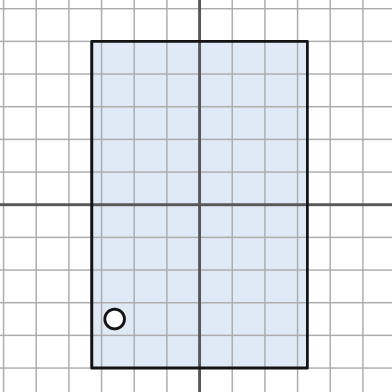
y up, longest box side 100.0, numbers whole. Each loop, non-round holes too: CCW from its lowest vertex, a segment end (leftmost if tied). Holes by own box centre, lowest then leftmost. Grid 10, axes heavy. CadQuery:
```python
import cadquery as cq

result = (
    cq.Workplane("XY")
    .moveTo(-33.0, -50.0)
    .lineTo(33.0, -50.0)
    .lineTo(33.0, 50.0)
    .lineTo(-33.0, 50.0)
    .close()
    .moveTo(-26.0, -35.0)
    .circle(3.0)
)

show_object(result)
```